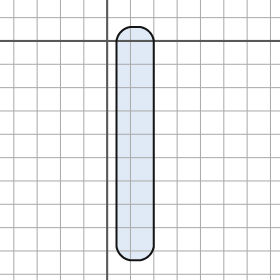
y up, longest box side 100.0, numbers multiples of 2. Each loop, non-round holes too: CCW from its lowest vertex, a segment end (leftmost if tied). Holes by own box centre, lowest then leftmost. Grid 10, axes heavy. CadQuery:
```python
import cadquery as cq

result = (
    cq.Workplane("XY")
    .moveTo(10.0, -94.0)
    .lineTo(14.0, -94.0)
    .threePointArc((18.0, -92.0), (20.0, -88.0))
    .lineTo(20.0, 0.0)
    .threePointArc((18.0, 4.0), (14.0, 6.0))
    .lineTo(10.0, 6.0)
    .threePointArc((6.0, 4.0), (4.0, 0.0))
    .lineTo(4.0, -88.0)
    .threePointArc((6.0, -92.0), (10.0, -94.0))
    .close()
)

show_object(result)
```